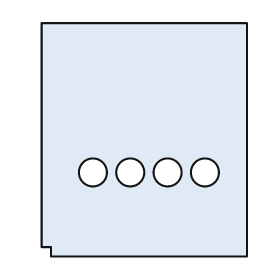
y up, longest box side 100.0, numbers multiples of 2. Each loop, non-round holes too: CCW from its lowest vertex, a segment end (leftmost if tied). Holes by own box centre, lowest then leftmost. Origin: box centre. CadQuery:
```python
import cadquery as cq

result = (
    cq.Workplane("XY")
    .moveTo(-40.0, -50.0)
    .lineTo(44.0, -50.0)
    .lineTo(44.0, 50.0)
    .lineTo(-44.0, 50.0)
    .lineTo(-44.0, -46.0)
    .lineTo(-40.0, -46.0)
    .close()
    .moveTo(-22.0, -14.0)
    .circle(6.0)
    .moveTo(-6.0, -14.0)
    .circle(6.0)
    .moveTo(10.0, -14.0)
    .circle(6.0)
    .moveTo(26.0, -14.0)
    .circle(6.0)
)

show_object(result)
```